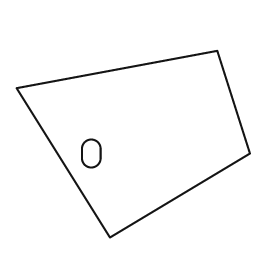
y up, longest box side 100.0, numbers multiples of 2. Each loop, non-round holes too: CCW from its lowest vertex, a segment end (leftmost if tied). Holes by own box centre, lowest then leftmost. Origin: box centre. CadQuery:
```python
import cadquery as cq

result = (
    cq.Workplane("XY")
    .moveTo(-10.0, -40.0)
    .lineTo(50.0, -4.0)
    .lineTo(36.0, 40.0)
    .lineTo(-50.0, 24.0)
    .close()
    .moveTo(-22.0, -6.0)
    .threePointArc((-18.0, -10.0), (-14.0, -6.0))
    .lineTo(-14.0, -2.0)
    .threePointArc((-18.0, 2.0), (-22.0, -2.0))
    .close()
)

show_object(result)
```